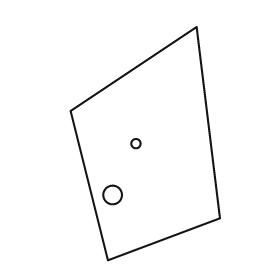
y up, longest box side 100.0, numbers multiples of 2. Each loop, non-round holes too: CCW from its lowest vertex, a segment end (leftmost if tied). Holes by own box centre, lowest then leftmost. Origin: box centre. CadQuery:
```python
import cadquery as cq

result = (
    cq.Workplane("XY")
    .moveTo(-16.0, -50.0)
    .lineTo(32.0, -32.0)
    .lineTo(22.0, 50.0)
    .lineTo(-32.0, 14.0)
    .close()
    .moveTo(-14.0, -22.0)
    .circle(4.0)
    .moveTo(-4.0, 0.0)
    .circle(2.0)
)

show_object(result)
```